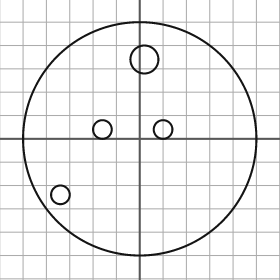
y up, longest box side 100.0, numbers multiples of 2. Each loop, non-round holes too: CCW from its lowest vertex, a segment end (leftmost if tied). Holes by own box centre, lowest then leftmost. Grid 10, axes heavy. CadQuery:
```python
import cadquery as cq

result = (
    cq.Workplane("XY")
    .moveTo(0.0, 0.0)
    .circle(50.0)
    .moveTo(-34.0, -24.0)
    .circle(4.0)
    .moveTo(-16.0, 4.0)
    .circle(4.0)
    .moveTo(10.0, 4.0)
    .circle(4.0)
    .moveTo(2.0, 34.0)
    .circle(6.0)
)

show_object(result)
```